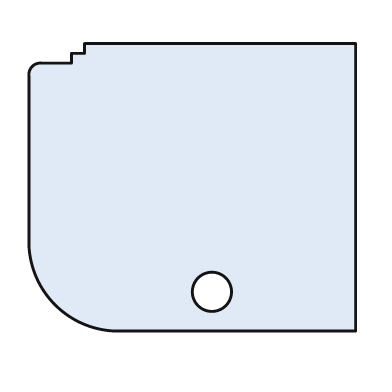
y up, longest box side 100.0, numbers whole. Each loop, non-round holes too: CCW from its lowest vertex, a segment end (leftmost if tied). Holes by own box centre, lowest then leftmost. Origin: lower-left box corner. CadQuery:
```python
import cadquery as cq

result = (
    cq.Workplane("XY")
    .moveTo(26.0, 0.0)
    .lineTo(100.0, 0.0)
    .lineTo(100.0, 88.0)
    .lineTo(17.0, 88.0)
    .lineTo(17.0, 85.0)
    .lineTo(13.0, 85.0)
    .lineTo(13.0, 82.0)
    .lineTo(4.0, 82.0)
    .threePointArc((1.0, 81.0), (0.0, 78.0))
    .lineTo(0.0, 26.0)
    .threePointArc((8.0, 8.0), (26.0, 0.0))
    .close()
    .moveTo(56.0, 12.0)
    .circle(6.0)
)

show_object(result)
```